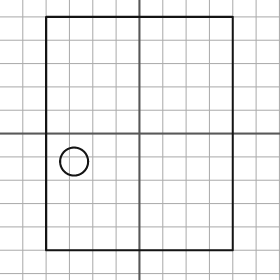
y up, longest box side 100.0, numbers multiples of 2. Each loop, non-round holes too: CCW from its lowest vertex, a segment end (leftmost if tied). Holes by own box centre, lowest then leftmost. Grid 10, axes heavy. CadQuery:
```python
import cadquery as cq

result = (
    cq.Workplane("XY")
    .moveTo(-40.0, -50.0)
    .lineTo(40.0, -50.0)
    .lineTo(40.0, 50.0)
    .lineTo(-40.0, 50.0)
    .close()
    .moveTo(-28.0, -12.0)
    .circle(6.0)
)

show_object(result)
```